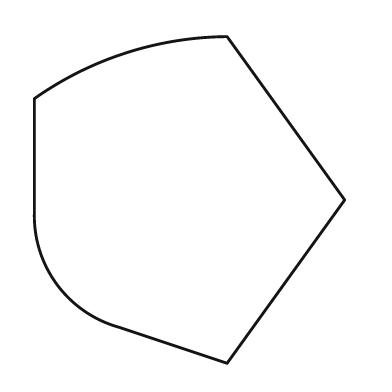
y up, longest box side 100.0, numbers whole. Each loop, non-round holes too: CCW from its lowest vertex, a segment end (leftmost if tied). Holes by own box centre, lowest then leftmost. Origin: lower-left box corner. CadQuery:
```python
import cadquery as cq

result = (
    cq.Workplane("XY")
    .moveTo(59.0, 0.0)
    .lineTo(95.0, 50.0)
    .lineTo(59.0, 100.0)
    .threePointArc((28.0, 95.0), (0.0, 81.0))
    .lineTo(0.0, 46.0)
    .threePointArc((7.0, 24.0), (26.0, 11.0))
    .close()
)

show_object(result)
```